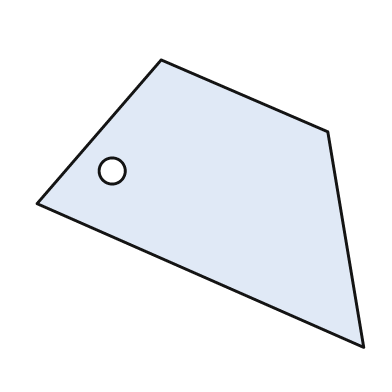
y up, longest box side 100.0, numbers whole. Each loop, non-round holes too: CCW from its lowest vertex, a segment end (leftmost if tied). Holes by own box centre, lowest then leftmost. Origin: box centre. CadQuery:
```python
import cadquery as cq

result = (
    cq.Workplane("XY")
    .moveTo(50.0, -44.0)
    .lineTo(39.0, 22.0)
    .lineTo(-12.0, 44.0)
    .lineTo(-50.0, 0.0)
    .close()
    .moveTo(-27.0, 10.0)
    .circle(4.0)
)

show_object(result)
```